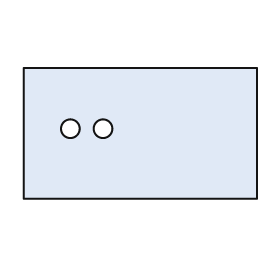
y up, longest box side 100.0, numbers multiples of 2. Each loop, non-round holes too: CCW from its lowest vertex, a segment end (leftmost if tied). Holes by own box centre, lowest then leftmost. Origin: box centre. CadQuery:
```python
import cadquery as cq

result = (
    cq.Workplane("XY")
    .moveTo(-50.0, -28.0)
    .lineTo(50.0, -28.0)
    .lineTo(50.0, 28.0)
    .lineTo(-50.0, 28.0)
    .close()
    .moveTo(-30.0, 2.0)
    .circle(4.0)
    .moveTo(-16.0, 2.0)
    .circle(4.0)
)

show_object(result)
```